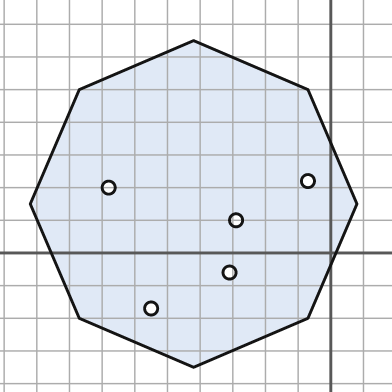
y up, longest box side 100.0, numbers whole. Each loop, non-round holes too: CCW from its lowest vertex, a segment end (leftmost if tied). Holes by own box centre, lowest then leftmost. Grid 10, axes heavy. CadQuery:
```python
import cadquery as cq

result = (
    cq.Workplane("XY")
    .moveTo(-42.0, -35.0)
    .lineTo(-7.0, -20.0)
    .lineTo(8.0, 15.0)
    .lineTo(-7.0, 50.0)
    .lineTo(-42.0, 65.0)
    .lineTo(-77.0, 50.0)
    .lineTo(-92.0, 15.0)
    .lineTo(-77.0, -20.0)
    .close()
    .moveTo(-55.0, -17.0)
    .circle(2.0)
    .moveTo(-31.0, -6.0)
    .circle(2.0)
    .moveTo(-29.0, 10.0)
    .circle(2.0)
    .moveTo(-68.0, 20.0)
    .circle(2.0)
    .moveTo(-7.0, 22.0)
    .circle(2.0)
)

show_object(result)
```